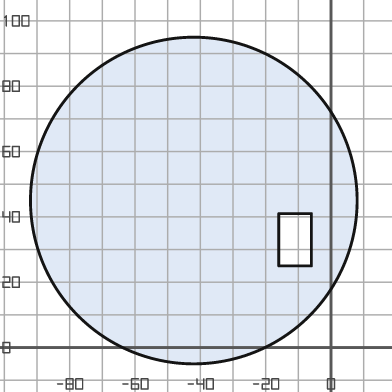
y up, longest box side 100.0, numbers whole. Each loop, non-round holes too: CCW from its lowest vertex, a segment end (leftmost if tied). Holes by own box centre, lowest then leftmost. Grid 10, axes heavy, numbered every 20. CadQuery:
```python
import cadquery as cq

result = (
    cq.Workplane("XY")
    .moveTo(-42.0, 45.0)
    .circle(50.0)
    .moveTo(-16.0, 25.0)
    .lineTo(-6.0, 25.0)
    .lineTo(-6.0, 41.0)
    .lineTo(-16.0, 41.0)
    .close()
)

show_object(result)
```